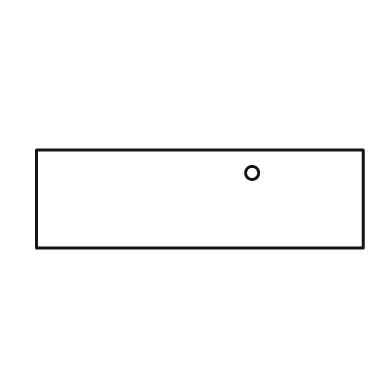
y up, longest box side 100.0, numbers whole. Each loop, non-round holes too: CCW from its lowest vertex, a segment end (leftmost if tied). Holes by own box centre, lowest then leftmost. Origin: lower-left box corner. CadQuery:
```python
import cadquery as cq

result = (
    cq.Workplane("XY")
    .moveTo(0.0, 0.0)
    .lineTo(100.0, 0.0)
    .lineTo(100.0, 30.0)
    .lineTo(0.0, 30.0)
    .close()
    .moveTo(66.0, 23.0)
    .circle(2.0)
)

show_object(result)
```